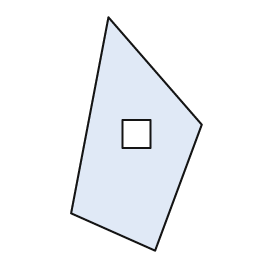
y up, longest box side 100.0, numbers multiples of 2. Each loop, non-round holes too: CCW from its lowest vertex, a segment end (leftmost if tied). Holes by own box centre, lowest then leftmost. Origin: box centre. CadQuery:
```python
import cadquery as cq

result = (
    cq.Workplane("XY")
    .moveTo(8.0, -50.0)
    .lineTo(28.0, 4.0)
    .lineTo(-12.0, 50.0)
    .lineTo(-28.0, -34.0)
    .close()
    .moveTo(-6.0, -6.0)
    .lineTo(6.0, -6.0)
    .lineTo(6.0, 6.0)
    .lineTo(-6.0, 6.0)
    .close()
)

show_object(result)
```